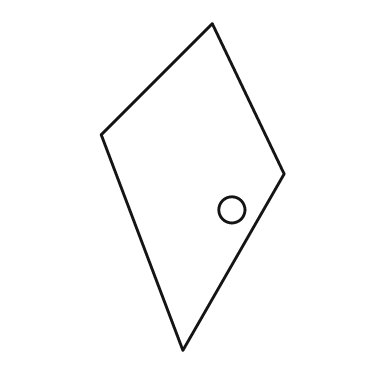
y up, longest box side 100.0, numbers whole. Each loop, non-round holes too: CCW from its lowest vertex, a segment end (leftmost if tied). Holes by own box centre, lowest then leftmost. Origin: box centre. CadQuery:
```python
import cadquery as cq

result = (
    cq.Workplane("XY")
    .moveTo(-3.0, -50.0)
    .lineTo(28.0, 4.0)
    .lineTo(6.0, 50.0)
    .lineTo(-28.0, 16.0)
    .close()
    .moveTo(12.0, -7.0)
    .circle(4.0)
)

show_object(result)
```